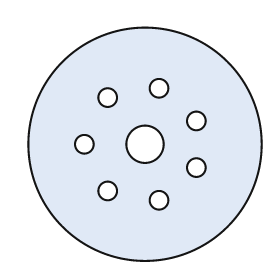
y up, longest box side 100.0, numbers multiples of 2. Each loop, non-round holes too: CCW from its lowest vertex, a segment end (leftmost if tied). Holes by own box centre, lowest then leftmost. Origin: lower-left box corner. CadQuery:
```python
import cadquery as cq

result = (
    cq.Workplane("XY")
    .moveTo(50.0, 50.0)
    .circle(50.0)
    .moveTo(56.0, 26.0)
    .circle(4.0)
    .moveTo(34.0, 30.0)
    .circle(4.0)
    .moveTo(72.0, 40.0)
    .circle(4.0)
    .moveTo(24.0, 50.0)
    .circle(4.0)
    .moveTo(50.0, 50.0)
    .circle(8.0)
    .moveTo(72.0, 60.0)
    .circle(4.0)
    .moveTo(34.0, 70.0)
    .circle(4.0)
    .moveTo(56.0, 74.0)
    .circle(4.0)
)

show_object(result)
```